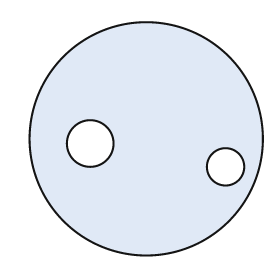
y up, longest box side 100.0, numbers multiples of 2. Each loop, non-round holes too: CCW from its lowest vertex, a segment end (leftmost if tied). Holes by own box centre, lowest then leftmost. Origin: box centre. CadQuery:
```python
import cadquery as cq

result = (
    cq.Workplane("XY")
    .moveTo(0.0, 0.0)
    .circle(50.0)
    .moveTo(34.0, -12.0)
    .circle(8.0)
    .moveTo(-24.0, -2.0)
    .circle(10.0)
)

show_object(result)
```